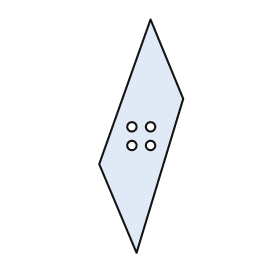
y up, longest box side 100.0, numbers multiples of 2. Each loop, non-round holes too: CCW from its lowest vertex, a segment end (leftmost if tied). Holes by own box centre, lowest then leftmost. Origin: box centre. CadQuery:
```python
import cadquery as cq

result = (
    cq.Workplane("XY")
    .moveTo(-2.0, -50.0)
    .lineTo(18.0, 16.0)
    .lineTo(4.0, 50.0)
    .lineTo(-18.0, -12.0)
    .close()
    .moveTo(-4.0, -4.0)
    .circle(2.0)
    .moveTo(4.0, -4.0)
    .circle(2.0)
    .moveTo(-4.0, 4.0)
    .circle(2.0)
    .moveTo(4.0, 4.0)
    .circle(2.0)
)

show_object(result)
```